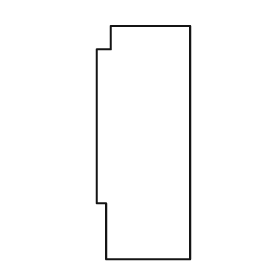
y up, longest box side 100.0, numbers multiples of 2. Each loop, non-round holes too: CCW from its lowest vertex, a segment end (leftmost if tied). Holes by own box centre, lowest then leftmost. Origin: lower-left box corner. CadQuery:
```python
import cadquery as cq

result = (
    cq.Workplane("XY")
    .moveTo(4.0, 0.0)
    .lineTo(40.0, 0.0)
    .lineTo(40.0, 100.0)
    .lineTo(6.0, 100.0)
    .lineTo(6.0, 90.0)
    .lineTo(0.0, 90.0)
    .lineTo(0.0, 24.0)
    .lineTo(4.0, 24.0)
    .close()
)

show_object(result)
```